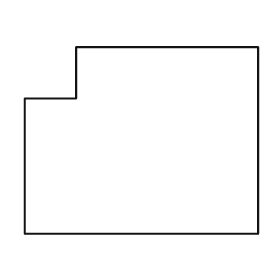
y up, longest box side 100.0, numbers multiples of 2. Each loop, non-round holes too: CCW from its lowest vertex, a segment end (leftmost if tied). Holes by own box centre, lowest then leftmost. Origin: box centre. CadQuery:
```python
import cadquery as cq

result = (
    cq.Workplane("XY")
    .moveTo(-50.0, -40.0)
    .lineTo(50.0, -40.0)
    .lineTo(50.0, 40.0)
    .lineTo(-28.0, 40.0)
    .lineTo(-28.0, 18.0)
    .lineTo(-50.0, 18.0)
    .close()
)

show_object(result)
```